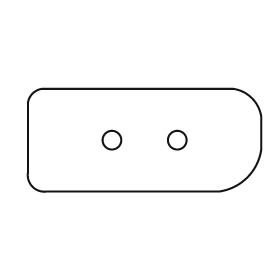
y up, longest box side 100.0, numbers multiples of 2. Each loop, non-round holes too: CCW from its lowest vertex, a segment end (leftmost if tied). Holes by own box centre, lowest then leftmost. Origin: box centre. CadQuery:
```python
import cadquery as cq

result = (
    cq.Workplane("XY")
    .moveTo(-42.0, -22.0)
    .lineTo(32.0, -22.0)
    .threePointArc((44.0, -16.0), (50.0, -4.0))
    .lineTo(50.0, 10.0)
    .threePointArc((46.0, 18.0), (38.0, 22.0))
    .lineTo(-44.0, 22.0)
    .threePointArc((-48.0, 20.0), (-50.0, 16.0))
    .lineTo(-50.0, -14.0)
    .threePointArc((-48.0, -20.0), (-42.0, -22.0))
    .close()
    .moveTo(-14.0, 0.0)
    .circle(4.0)
    .moveTo(14.0, 0.0)
    .circle(4.0)
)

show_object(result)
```